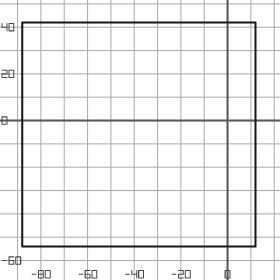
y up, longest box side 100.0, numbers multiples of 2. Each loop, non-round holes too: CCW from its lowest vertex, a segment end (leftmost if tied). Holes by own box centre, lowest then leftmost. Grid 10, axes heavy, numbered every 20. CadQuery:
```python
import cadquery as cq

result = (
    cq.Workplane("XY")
    .moveTo(-88.0, -54.0)
    .lineTo(12.0, -54.0)
    .lineTo(12.0, 42.0)
    .lineTo(-88.0, 42.0)
    .close()
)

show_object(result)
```